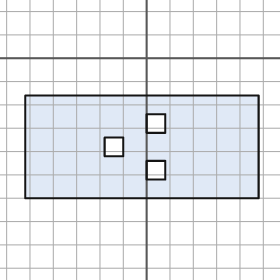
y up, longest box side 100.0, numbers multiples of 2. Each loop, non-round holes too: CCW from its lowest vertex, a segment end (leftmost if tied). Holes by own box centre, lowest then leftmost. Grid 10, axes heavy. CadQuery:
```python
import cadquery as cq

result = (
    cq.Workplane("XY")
    .moveTo(-52.0, -60.0)
    .lineTo(48.0, -60.0)
    .lineTo(48.0, -16.0)
    .lineTo(-52.0, -16.0)
    .close()
    .moveTo(0.0, -52.0)
    .lineTo(8.0, -52.0)
    .lineTo(8.0, -44.0)
    .lineTo(0.0, -44.0)
    .close()
    .moveTo(-18.0, -42.0)
    .lineTo(-10.0, -42.0)
    .lineTo(-10.0, -34.0)
    .lineTo(-18.0, -34.0)
    .close()
    .moveTo(0.0, -32.0)
    .lineTo(8.0, -32.0)
    .lineTo(8.0, -24.0)
    .lineTo(0.0, -24.0)
    .close()
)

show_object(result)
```